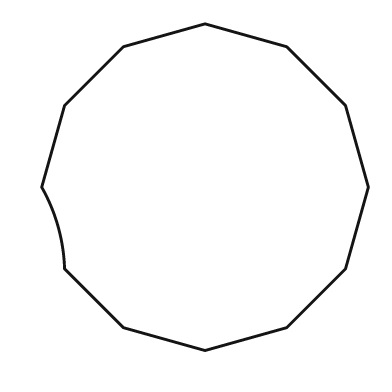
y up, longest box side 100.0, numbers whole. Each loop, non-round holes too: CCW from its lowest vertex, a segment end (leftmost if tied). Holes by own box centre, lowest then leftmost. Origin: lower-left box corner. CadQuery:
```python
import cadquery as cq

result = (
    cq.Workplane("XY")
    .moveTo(50.0, 0.0)
    .lineTo(75.0, 7.0)
    .lineTo(93.0, 25.0)
    .lineTo(100.0, 50.0)
    .lineTo(93.0, 75.0)
    .lineTo(75.0, 93.0)
    .lineTo(50.0, 100.0)
    .lineTo(25.0, 93.0)
    .lineTo(7.0, 75.0)
    .lineTo(0.0, 50.0)
    .threePointArc((5.0, 38.0), (7.0, 25.0))
    .lineTo(25.0, 7.0)
    .close()
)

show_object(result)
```